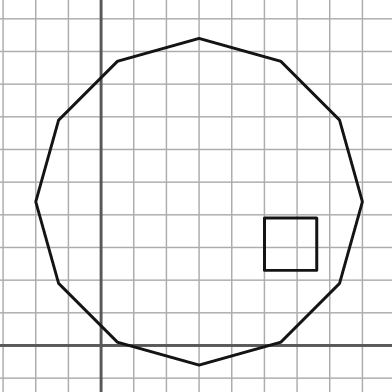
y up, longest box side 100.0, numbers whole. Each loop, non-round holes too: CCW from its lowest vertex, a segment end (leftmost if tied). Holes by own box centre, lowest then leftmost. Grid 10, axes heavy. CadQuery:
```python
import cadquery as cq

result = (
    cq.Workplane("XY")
    .moveTo(30.0, -6.0)
    .lineTo(55.0, 1.0)
    .lineTo(73.0, 19.0)
    .lineTo(80.0, 44.0)
    .lineTo(73.0, 69.0)
    .lineTo(55.0, 87.0)
    .lineTo(30.0, 94.0)
    .lineTo(5.0, 87.0)
    .lineTo(-13.0, 69.0)
    .lineTo(-20.0, 44.0)
    .lineTo(-13.0, 19.0)
    .lineTo(5.0, 1.0)
    .close()
    .moveTo(50.0, 23.0)
    .lineTo(66.0, 23.0)
    .lineTo(66.0, 39.0)
    .lineTo(50.0, 39.0)
    .close()
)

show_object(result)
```